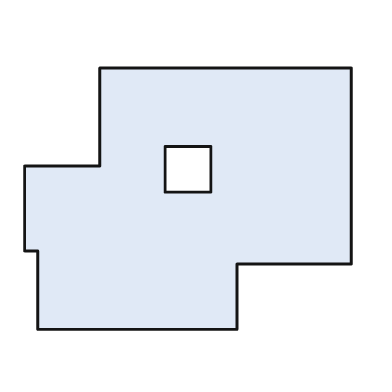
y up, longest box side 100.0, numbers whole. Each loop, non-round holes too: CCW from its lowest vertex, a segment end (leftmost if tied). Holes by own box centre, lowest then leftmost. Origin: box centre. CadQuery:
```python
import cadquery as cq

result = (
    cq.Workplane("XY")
    .moveTo(-46.0, -40.0)
    .lineTo(15.0, -40.0)
    .lineTo(15.0, -20.0)
    .lineTo(50.0, -20.0)
    .lineTo(50.0, 40.0)
    .lineTo(-27.0, 40.0)
    .lineTo(-27.0, 10.0)
    .lineTo(-50.0, 10.0)
    .lineTo(-50.0, -16.0)
    .lineTo(-46.0, -16.0)
    .close()
    .moveTo(-7.0, 2.0)
    .lineTo(7.0, 2.0)
    .lineTo(7.0, 16.0)
    .lineTo(-7.0, 16.0)
    .close()
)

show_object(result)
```